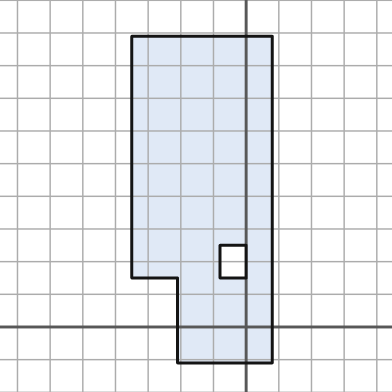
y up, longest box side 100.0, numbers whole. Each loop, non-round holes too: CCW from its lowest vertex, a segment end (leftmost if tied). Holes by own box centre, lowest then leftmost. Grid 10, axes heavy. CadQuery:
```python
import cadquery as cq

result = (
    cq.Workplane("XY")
    .moveTo(-21.0, -11.0)
    .lineTo(8.0, -11.0)
    .lineTo(8.0, 89.0)
    .lineTo(-35.0, 89.0)
    .lineTo(-35.0, 15.0)
    .lineTo(-21.0, 15.0)
    .close()
    .moveTo(-8.0, 15.0)
    .lineTo(0.0, 15.0)
    .lineTo(0.0, 25.0)
    .lineTo(-8.0, 25.0)
    .close()
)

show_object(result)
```